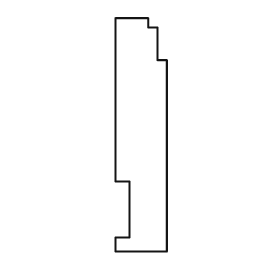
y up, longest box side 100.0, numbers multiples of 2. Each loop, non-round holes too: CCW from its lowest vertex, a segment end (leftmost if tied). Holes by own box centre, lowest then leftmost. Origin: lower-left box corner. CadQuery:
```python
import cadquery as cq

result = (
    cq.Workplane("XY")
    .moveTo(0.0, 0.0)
    .lineTo(22.0, 0.0)
    .lineTo(22.0, 82.0)
    .lineTo(18.0, 82.0)
    .lineTo(18.0, 96.0)
    .lineTo(14.0, 96.0)
    .lineTo(14.0, 100.0)
    .lineTo(0.0, 100.0)
    .lineTo(0.0, 30.0)
    .lineTo(6.0, 30.0)
    .lineTo(6.0, 6.0)
    .lineTo(0.0, 6.0)
    .close()
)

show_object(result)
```